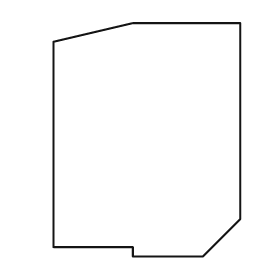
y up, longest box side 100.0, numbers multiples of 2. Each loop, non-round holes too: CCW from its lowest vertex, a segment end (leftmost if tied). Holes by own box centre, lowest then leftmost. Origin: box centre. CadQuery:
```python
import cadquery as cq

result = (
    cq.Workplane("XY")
    .moveTo(-6.0, -50.0)
    .lineTo(24.0, -50.0)
    .lineTo(40.0, -34.0)
    .lineTo(40.0, 50.0)
    .lineTo(-6.0, 50.0)
    .lineTo(-40.0, 42.0)
    .lineTo(-40.0, -46.0)
    .lineTo(-6.0, -46.0)
    .close()
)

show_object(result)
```